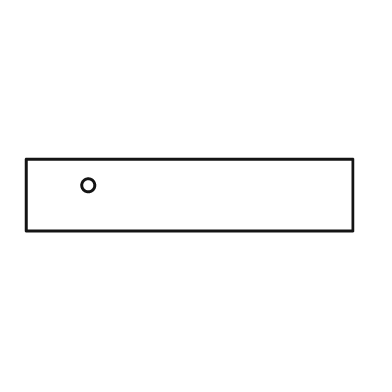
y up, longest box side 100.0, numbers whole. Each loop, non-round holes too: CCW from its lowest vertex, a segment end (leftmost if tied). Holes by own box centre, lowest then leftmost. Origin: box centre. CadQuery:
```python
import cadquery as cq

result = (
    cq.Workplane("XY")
    .moveTo(-50.0, -11.0)
    .lineTo(50.0, -11.0)
    .lineTo(50.0, 11.0)
    .lineTo(-50.0, 11.0)
    .close()
    .moveTo(-31.0, 3.0)
    .circle(2.0)
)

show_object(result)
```